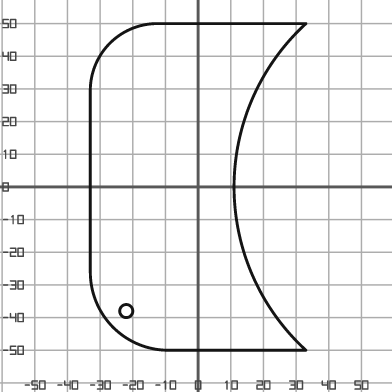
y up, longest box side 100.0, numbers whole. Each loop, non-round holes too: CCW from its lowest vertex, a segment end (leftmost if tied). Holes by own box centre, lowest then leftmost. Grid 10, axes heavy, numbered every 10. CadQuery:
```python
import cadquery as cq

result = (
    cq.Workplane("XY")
    .moveTo(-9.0, -50.0)
    .lineTo(33.0, -50.0)
    .threePointArc((11.0, 0.0), (33.0, 50.0))
    .lineTo(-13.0, 50.0)
    .threePointArc((-27.0, 44.0), (-33.0, 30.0))
    .lineTo(-33.0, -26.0)
    .threePointArc((-26.0, -43.0), (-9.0, -50.0))
    .close()
    .moveTo(-22.0, -38.0)
    .circle(2.0)
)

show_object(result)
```